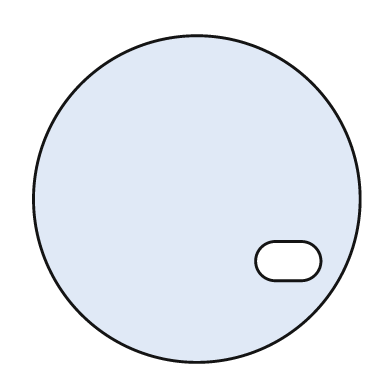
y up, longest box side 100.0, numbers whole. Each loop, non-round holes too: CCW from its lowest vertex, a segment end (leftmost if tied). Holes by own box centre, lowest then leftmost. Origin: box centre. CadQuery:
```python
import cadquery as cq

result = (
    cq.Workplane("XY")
    .moveTo(0.0, 0.0)
    .circle(50.0)
    .moveTo(24.0, -25.0)
    .lineTo(32.0, -25.0)
    .threePointArc((38.0, -19.0), (32.0, -13.0))
    .lineTo(24.0, -13.0)
    .threePointArc((18.0, -19.0), (24.0, -25.0))
    .close()
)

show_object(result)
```